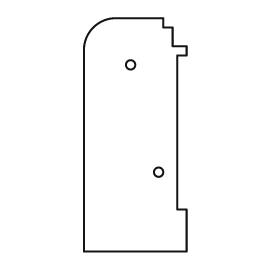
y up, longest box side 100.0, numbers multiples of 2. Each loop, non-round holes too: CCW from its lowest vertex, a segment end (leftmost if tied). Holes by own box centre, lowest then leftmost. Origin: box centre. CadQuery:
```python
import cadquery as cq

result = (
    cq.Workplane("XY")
    .moveTo(-22.0, -50.0)
    .lineTo(22.0, -50.0)
    .lineTo(22.0, -32.0)
    .lineTo(18.0, -32.0)
    .lineTo(18.0, 34.0)
    .lineTo(22.0, 34.0)
    .lineTo(22.0, 38.0)
    .lineTo(16.0, 38.0)
    .lineTo(16.0, 46.0)
    .lineTo(12.0, 46.0)
    .lineTo(12.0, 50.0)
    .lineTo(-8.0, 50.0)
    .threePointArc((-18.0, 46.0), (-22.0, 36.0))
    .close()
    .moveTo(10.0, -16.0)
    .circle(2.0)
    .moveTo(-2.0, 30.0)
    .circle(2.0)
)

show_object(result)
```